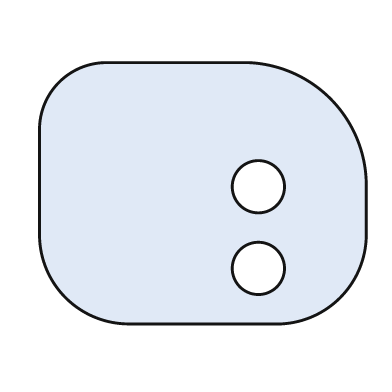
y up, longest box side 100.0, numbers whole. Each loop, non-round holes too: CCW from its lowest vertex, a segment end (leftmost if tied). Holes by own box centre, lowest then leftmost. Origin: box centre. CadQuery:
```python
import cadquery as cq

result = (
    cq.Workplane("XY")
    .moveTo(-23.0, -40.0)
    .lineTo(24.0, -40.0)
    .threePointArc((42.0, -32.0), (50.0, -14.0))
    .lineTo(50.0, 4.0)
    .threePointArc((39.0, 29.0), (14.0, 40.0))
    .lineTo(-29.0, 40.0)
    .threePointArc((-44.0, 34.0), (-50.0, 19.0))
    .lineTo(-50.0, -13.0)
    .threePointArc((-42.0, -32.0), (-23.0, -40.0))
    .close()
    .moveTo(17.0, -23.0)
    .circle(8.0)
    .moveTo(17.0, 2.0)
    .circle(8.0)
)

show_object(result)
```